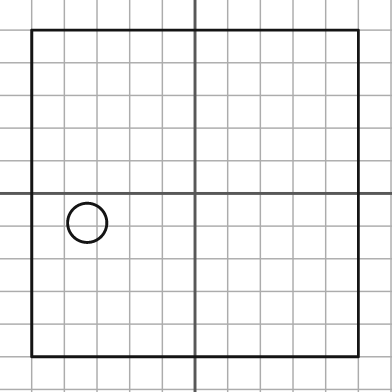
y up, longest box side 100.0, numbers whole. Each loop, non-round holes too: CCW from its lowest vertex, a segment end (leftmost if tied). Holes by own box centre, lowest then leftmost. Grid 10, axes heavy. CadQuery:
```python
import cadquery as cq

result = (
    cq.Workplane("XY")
    .moveTo(-50.0, -50.0)
    .lineTo(50.0, -50.0)
    .lineTo(50.0, 50.0)
    .lineTo(-50.0, 50.0)
    .close()
    .moveTo(-33.0, -9.0)
    .circle(6.0)
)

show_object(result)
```